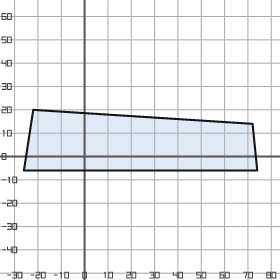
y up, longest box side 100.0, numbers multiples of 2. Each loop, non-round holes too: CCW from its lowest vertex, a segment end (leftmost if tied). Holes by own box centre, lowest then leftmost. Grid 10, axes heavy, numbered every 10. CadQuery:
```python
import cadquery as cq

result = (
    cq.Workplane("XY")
    .moveTo(-26.0, -6.0)
    .lineTo(74.0, -6.0)
    .lineTo(72.0, 14.0)
    .lineTo(-22.0, 20.0)
    .close()
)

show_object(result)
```